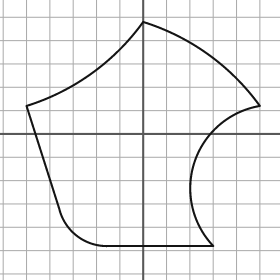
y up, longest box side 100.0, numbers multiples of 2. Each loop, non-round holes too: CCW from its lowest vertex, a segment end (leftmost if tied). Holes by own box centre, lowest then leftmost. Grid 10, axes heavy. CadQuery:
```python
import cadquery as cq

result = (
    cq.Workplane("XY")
    .moveTo(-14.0, -48.0)
    .lineTo(30.0, -48.0)
    .threePointArc((22.0, -12.0), (50.0, 12.0))
    .threePointArc((28.0, 34.0), (0.0, 48.0))
    .threePointArc((-22.0, 26.0), (-50.0, 12.0))
    .lineTo(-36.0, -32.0)
    .threePointArc((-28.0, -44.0), (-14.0, -48.0))
    .close()
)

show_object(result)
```